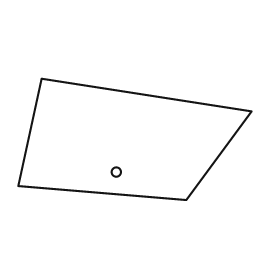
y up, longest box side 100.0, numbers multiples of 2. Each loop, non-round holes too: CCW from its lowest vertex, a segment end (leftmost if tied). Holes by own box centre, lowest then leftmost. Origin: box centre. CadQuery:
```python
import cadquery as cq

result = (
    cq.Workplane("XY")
    .moveTo(22.0, -26.0)
    .lineTo(50.0, 12.0)
    .lineTo(-40.0, 26.0)
    .lineTo(-50.0, -20.0)
    .close()
    .moveTo(-8.0, -14.0)
    .circle(2.0)
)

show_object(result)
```